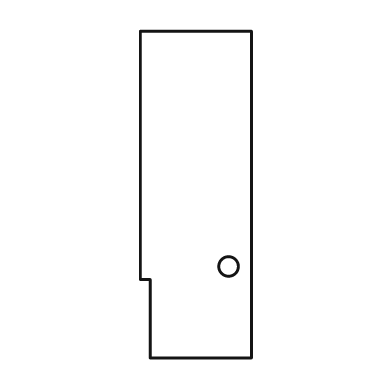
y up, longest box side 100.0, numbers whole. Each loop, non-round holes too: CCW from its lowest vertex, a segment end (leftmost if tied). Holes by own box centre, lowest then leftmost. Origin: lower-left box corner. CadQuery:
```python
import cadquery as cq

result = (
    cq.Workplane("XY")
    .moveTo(3.0, 0.0)
    .lineTo(34.0, 0.0)
    .lineTo(34.0, 100.0)
    .lineTo(0.0, 100.0)
    .lineTo(0.0, 24.0)
    .lineTo(3.0, 24.0)
    .close()
    .moveTo(27.0, 28.0)
    .circle(3.0)
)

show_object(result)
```